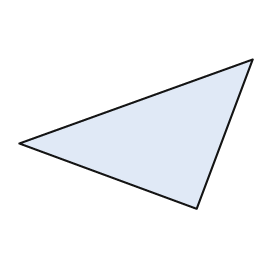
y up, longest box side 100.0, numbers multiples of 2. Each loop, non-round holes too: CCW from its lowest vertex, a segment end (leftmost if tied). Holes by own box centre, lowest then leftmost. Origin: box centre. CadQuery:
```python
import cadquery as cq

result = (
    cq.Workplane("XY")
    .moveTo(26.0, -32.0)
    .lineTo(50.0, 32.0)
    .lineTo(-50.0, -4.0)
    .close()
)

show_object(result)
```